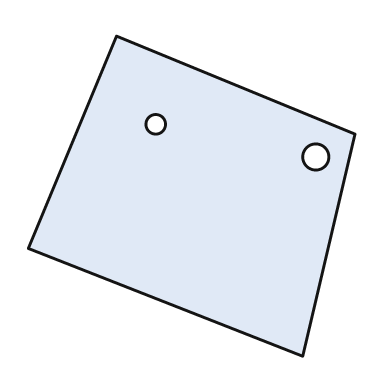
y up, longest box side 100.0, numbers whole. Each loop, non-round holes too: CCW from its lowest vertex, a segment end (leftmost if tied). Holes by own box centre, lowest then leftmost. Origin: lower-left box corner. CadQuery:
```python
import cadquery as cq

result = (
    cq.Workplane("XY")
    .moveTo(84.0, 0.0)
    .lineTo(100.0, 68.0)
    .lineTo(27.0, 98.0)
    .lineTo(0.0, 33.0)
    .close()
    .moveTo(88.0, 61.0)
    .circle(4.0)
    .moveTo(39.0, 71.0)
    .circle(3.0)
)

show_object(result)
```